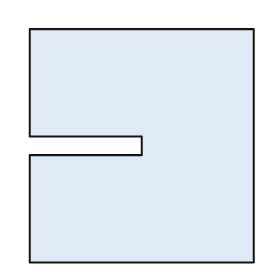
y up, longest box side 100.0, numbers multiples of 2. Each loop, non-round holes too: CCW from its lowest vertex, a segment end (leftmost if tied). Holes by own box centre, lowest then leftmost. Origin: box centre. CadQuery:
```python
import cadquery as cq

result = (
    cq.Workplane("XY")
    .moveTo(-48.0, -50.0)
    .lineTo(48.0, -50.0)
    .lineTo(48.0, 50.0)
    .lineTo(-48.0, 50.0)
    .lineTo(-48.0, 4.0)
    .lineTo(0.0, 4.0)
    .lineTo(0.0, -4.0)
    .lineTo(-48.0, -4.0)
    .close()
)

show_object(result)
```